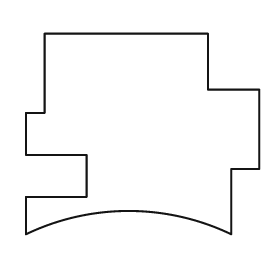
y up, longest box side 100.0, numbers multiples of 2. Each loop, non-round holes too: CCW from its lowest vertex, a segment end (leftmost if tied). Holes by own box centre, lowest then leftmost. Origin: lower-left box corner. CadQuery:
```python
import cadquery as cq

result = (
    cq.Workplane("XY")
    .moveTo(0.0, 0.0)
    .threePointArc((44.0, 10.0), (88.0, 0.0))
    .lineTo(88.0, 28.0)
    .lineTo(100.0, 28.0)
    .lineTo(100.0, 62.0)
    .lineTo(78.0, 62.0)
    .lineTo(78.0, 86.0)
    .lineTo(8.0, 86.0)
    .lineTo(8.0, 52.0)
    .lineTo(0.0, 52.0)
    .lineTo(0.0, 34.0)
    .lineTo(26.0, 34.0)
    .lineTo(26.0, 16.0)
    .lineTo(0.0, 16.0)
    .close()
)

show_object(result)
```